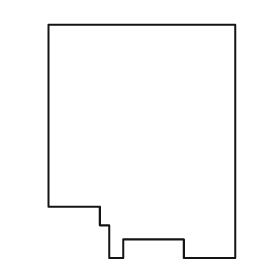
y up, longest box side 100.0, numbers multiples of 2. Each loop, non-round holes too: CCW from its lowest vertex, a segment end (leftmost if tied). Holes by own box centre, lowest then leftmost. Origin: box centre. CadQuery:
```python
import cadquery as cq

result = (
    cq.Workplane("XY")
    .moveTo(-14.0, -50.0)
    .lineTo(-8.0, -50.0)
    .lineTo(-8.0, -42.0)
    .lineTo(18.0, -42.0)
    .lineTo(18.0, -50.0)
    .lineTo(40.0, -50.0)
    .lineTo(40.0, 50.0)
    .lineTo(-40.0, 50.0)
    .lineTo(-40.0, -28.0)
    .lineTo(-18.0, -28.0)
    .lineTo(-18.0, -36.0)
    .lineTo(-14.0, -36.0)
    .close()
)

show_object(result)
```